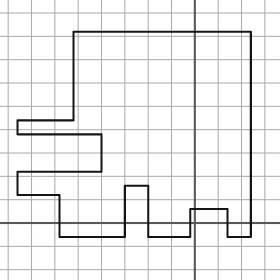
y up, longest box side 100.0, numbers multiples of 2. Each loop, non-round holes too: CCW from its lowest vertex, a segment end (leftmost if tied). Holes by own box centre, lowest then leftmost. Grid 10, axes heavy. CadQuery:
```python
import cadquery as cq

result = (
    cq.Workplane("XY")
    .moveTo(-58.0, -6.0)
    .lineTo(-30.0, -6.0)
    .lineTo(-30.0, 16.0)
    .lineTo(-20.0, 16.0)
    .lineTo(-20.0, -6.0)
    .lineTo(-2.0, -6.0)
    .lineTo(-2.0, 6.0)
    .lineTo(14.0, 6.0)
    .lineTo(14.0, -6.0)
    .lineTo(24.0, -6.0)
    .lineTo(24.0, 82.0)
    .lineTo(-52.0, 82.0)
    .lineTo(-52.0, 44.0)
    .lineTo(-76.0, 44.0)
    .lineTo(-76.0, 38.0)
    .lineTo(-40.0, 38.0)
    .lineTo(-40.0, 22.0)
    .lineTo(-76.0, 22.0)
    .lineTo(-76.0, 12.0)
    .lineTo(-58.0, 12.0)
    .close()
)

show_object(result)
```